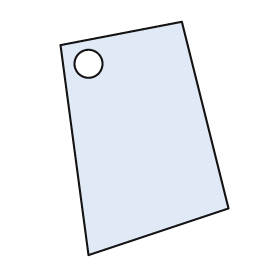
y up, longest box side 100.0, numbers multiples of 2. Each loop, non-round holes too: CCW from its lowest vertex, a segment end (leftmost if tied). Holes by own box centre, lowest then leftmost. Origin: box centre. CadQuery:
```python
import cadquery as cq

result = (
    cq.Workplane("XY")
    .moveTo(-24.0, -50.0)
    .lineTo(36.0, -30.0)
    .lineTo(16.0, 50.0)
    .lineTo(-36.0, 40.0)
    .close()
    .moveTo(-24.0, 32.0)
    .circle(6.0)
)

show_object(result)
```